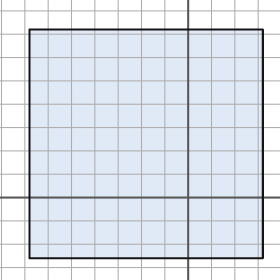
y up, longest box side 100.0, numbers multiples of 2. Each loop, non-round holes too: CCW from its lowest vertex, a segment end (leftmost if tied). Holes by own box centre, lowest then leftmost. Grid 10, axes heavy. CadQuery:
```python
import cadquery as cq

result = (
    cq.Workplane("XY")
    .moveTo(-68.0, -26.0)
    .lineTo(32.0, -26.0)
    .lineTo(32.0, 72.0)
    .lineTo(-68.0, 72.0)
    .close()
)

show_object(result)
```